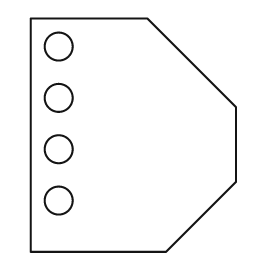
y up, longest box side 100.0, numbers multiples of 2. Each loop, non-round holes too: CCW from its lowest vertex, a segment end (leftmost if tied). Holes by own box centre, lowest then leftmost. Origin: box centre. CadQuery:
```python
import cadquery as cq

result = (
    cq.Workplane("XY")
    .moveTo(-44.0, -50.0)
    .lineTo(14.0, -50.0)
    .lineTo(44.0, -20.0)
    .lineTo(44.0, 12.0)
    .lineTo(6.0, 50.0)
    .lineTo(-44.0, 50.0)
    .close()
    .moveTo(-32.0, -28.0)
    .circle(6.0)
    .moveTo(-32.0, -6.0)
    .circle(6.0)
    .moveTo(-32.0, 16.0)
    .circle(6.0)
    .moveTo(-32.0, 38.0)
    .circle(6.0)
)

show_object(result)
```